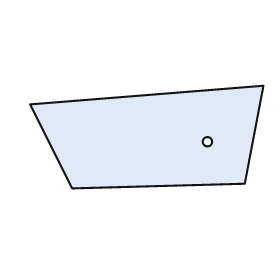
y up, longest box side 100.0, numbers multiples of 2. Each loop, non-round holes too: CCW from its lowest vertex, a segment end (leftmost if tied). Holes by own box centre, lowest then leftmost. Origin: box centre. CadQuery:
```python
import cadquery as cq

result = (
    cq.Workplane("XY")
    .moveTo(-32.0, -22.0)
    .lineTo(42.0, -20.0)
    .lineTo(50.0, 22.0)
    .lineTo(-50.0, 14.0)
    .close()
    .moveTo(26.0, -2.0)
    .circle(2.0)
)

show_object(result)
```